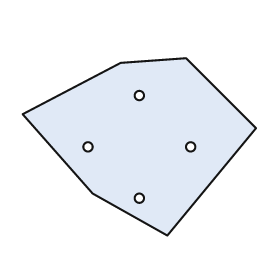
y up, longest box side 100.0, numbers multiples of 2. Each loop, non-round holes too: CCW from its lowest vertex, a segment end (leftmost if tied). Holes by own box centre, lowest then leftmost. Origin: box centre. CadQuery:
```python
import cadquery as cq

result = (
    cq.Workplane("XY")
    .moveTo(12.0, -38.0)
    .lineTo(50.0, 8.0)
    .lineTo(20.0, 38.0)
    .lineTo(-8.0, 36.0)
    .lineTo(-50.0, 14.0)
    .lineTo(-20.0, -20.0)
    .close()
    .moveTo(0.0, -22.0)
    .circle(2.0)
    .moveTo(-22.0, 0.0)
    .circle(2.0)
    .moveTo(22.0, 0.0)
    .circle(2.0)
    .moveTo(0.0, 22.0)
    .circle(2.0)
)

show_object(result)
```